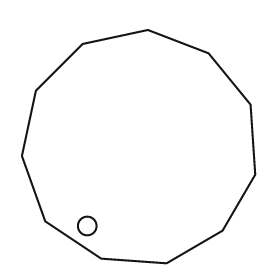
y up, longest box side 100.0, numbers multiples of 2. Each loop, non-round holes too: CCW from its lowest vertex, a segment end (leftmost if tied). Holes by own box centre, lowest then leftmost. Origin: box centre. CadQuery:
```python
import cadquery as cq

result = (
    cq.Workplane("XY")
    .moveTo(12.0, -50.0)
    .lineTo(36.0, -36.0)
    .lineTo(50.0, -12.0)
    .lineTo(48.0, 18.0)
    .lineTo(30.0, 40.0)
    .lineTo(4.0, 50.0)
    .lineTo(-24.0, 44.0)
    .lineTo(-44.0, 24.0)
    .lineTo(-50.0, -4.0)
    .lineTo(-40.0, -32.0)
    .lineTo(-16.0, -48.0)
    .close()
    .moveTo(-22.0, -34.0)
    .circle(4.0)
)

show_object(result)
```